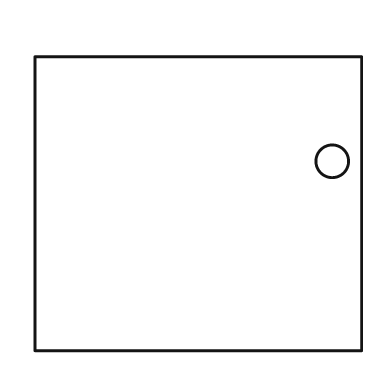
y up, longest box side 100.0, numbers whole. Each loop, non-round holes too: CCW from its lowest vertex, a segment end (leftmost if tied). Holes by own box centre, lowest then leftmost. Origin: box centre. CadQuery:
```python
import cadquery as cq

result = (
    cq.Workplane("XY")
    .moveTo(-50.0, -45.0)
    .lineTo(50.0, -45.0)
    .lineTo(50.0, 45.0)
    .lineTo(-50.0, 45.0)
    .close()
    .moveTo(41.0, 13.0)
    .circle(5.0)
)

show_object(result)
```